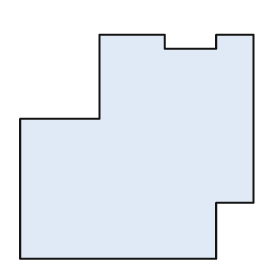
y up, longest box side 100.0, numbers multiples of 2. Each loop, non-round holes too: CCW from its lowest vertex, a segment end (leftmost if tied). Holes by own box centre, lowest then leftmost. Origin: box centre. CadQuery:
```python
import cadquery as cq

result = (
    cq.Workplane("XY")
    .moveTo(-50.0, -48.0)
    .lineTo(34.0, -48.0)
    .lineTo(34.0, -24.0)
    .lineTo(50.0, -24.0)
    .lineTo(50.0, 48.0)
    .lineTo(34.0, 48.0)
    .lineTo(34.0, 42.0)
    .lineTo(12.0, 42.0)
    .lineTo(12.0, 48.0)
    .lineTo(-16.0, 48.0)
    .lineTo(-16.0, 12.0)
    .lineTo(-50.0, 12.0)
    .close()
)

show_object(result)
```